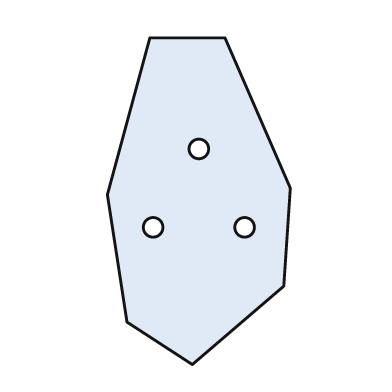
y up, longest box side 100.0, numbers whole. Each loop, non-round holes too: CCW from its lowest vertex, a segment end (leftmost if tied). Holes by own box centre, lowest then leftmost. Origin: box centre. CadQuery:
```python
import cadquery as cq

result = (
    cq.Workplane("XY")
    .moveTo(-2.0, -50.0)
    .lineTo(26.0, -26.0)
    .lineTo(28.0, 4.0)
    .lineTo(8.0, 50.0)
    .lineTo(-15.0, 50.0)
    .lineTo(-28.0, 2.0)
    .lineTo(-22.0, -37.0)
    .close()
    .moveTo(-14.0, -8.0)
    .circle(3.0)
    .moveTo(14.0, -8.0)
    .circle(3.0)
    .moveTo(0.0, 16.0)
    .circle(3.0)
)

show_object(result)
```